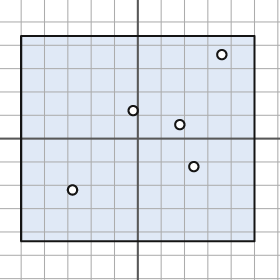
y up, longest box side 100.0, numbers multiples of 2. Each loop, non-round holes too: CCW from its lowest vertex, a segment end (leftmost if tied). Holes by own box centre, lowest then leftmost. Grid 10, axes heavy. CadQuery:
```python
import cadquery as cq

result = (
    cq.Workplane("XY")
    .moveTo(-50.0, -44.0)
    .lineTo(50.0, -44.0)
    .lineTo(50.0, 44.0)
    .lineTo(-50.0, 44.0)
    .close()
    .moveTo(-28.0, -22.0)
    .circle(2.0)
    .moveTo(24.0, -12.0)
    .circle(2.0)
    .moveTo(18.0, 6.0)
    .circle(2.0)
    .moveTo(-2.0, 12.0)
    .circle(2.0)
    .moveTo(36.0, 36.0)
    .circle(2.0)
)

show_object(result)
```